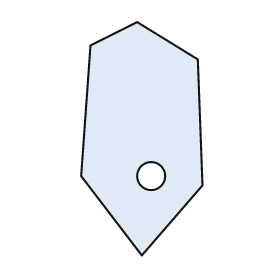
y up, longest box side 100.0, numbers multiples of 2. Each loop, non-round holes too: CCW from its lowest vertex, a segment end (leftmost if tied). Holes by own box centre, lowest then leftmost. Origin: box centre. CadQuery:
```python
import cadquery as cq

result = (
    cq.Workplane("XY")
    .moveTo(0.0, -50.0)
    .lineTo(26.0, -20.0)
    .lineTo(24.0, 34.0)
    .lineTo(-2.0, 50.0)
    .lineTo(-22.0, 40.0)
    .lineTo(-26.0, -16.0)
    .close()
    .moveTo(4.0, -16.0)
    .circle(6.0)
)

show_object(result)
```